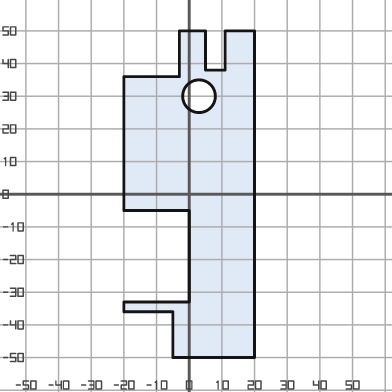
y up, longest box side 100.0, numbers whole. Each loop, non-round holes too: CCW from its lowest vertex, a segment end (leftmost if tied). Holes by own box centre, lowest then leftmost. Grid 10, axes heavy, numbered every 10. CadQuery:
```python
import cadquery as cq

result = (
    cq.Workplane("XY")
    .moveTo(-5.0, -50.0)
    .lineTo(20.0, -50.0)
    .lineTo(20.0, 50.0)
    .lineTo(11.0, 50.0)
    .lineTo(11.0, 38.0)
    .lineTo(5.0, 38.0)
    .lineTo(5.0, 50.0)
    .lineTo(-3.0, 50.0)
    .lineTo(-3.0, 36.0)
    .lineTo(-20.0, 36.0)
    .lineTo(-20.0, -5.0)
    .lineTo(0.0, -5.0)
    .lineTo(0.0, -33.0)
    .lineTo(-20.0, -33.0)
    .lineTo(-20.0, -36.0)
    .lineTo(-5.0, -36.0)
    .close()
    .moveTo(3.0, 30.0)
    .circle(5.0)
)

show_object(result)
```